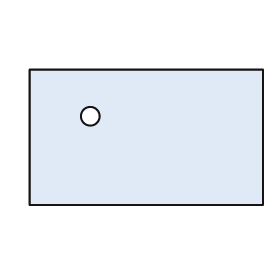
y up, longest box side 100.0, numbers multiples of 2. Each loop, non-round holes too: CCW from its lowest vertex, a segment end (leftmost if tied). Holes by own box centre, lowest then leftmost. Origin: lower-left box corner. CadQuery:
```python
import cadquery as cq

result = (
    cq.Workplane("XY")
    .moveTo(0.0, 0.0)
    .lineTo(100.0, 0.0)
    .lineTo(100.0, 58.0)
    .lineTo(0.0, 58.0)
    .close()
    .moveTo(26.0, 38.0)
    .circle(4.0)
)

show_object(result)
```